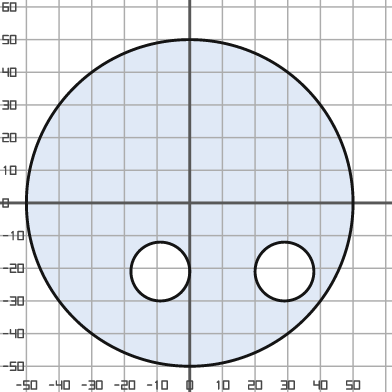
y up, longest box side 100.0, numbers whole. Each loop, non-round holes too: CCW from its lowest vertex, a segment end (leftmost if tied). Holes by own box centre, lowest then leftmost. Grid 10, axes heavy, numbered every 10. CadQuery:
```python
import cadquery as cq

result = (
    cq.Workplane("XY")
    .moveTo(0.0, 0.0)
    .circle(50.0)
    .moveTo(-9.0, -21.0)
    .circle(9.0)
    .moveTo(29.0, -21.0)
    .circle(9.0)
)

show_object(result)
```